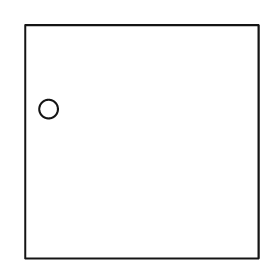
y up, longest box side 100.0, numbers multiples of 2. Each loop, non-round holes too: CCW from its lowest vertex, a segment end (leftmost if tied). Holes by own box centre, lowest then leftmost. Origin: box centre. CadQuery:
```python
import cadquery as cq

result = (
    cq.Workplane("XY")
    .moveTo(-50.0, -50.0)
    .lineTo(50.0, -50.0)
    .lineTo(50.0, 50.0)
    .lineTo(-50.0, 50.0)
    .close()
    .moveTo(-40.0, 14.0)
    .circle(4.0)
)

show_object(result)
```